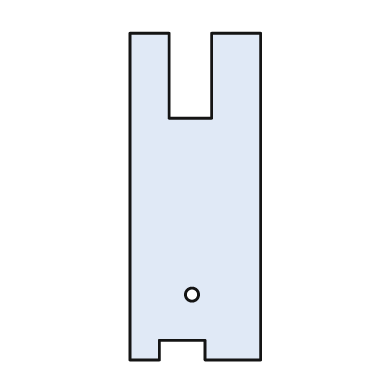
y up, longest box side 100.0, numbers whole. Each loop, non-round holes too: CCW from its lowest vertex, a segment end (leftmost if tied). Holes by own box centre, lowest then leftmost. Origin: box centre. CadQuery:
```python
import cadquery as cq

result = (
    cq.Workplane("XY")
    .moveTo(-20.0, -50.0)
    .lineTo(-11.0, -50.0)
    .lineTo(-11.0, -44.0)
    .lineTo(3.0, -44.0)
    .lineTo(3.0, -50.0)
    .lineTo(20.0, -50.0)
    .lineTo(20.0, 50.0)
    .lineTo(5.0, 50.0)
    .lineTo(5.0, 24.0)
    .lineTo(-8.0, 24.0)
    .lineTo(-8.0, 50.0)
    .lineTo(-20.0, 50.0)
    .close()
    .moveTo(-1.0, -30.0)
    .circle(2.0)
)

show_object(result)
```